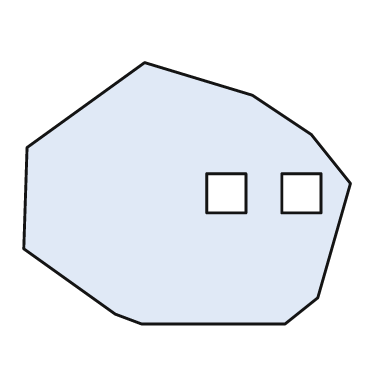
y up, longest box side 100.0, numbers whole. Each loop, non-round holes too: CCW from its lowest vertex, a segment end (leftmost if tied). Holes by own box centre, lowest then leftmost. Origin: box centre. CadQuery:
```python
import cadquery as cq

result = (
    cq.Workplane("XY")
    .moveTo(-14.0, -40.0)
    .lineTo(30.0, -40.0)
    .lineTo(40.0, -32.0)
    .lineTo(50.0, 3.0)
    .lineTo(38.0, 18.0)
    .lineTo(20.0, 30.0)
    .lineTo(-13.0, 40.0)
    .lineTo(-49.0, 14.0)
    .lineTo(-50.0, -17.0)
    .lineTo(-22.0, -37.0)
    .close()
    .moveTo(6.0, -6.0)
    .lineTo(18.0, -6.0)
    .lineTo(18.0, 6.0)
    .lineTo(6.0, 6.0)
    .close()
    .moveTo(29.0, -6.0)
    .lineTo(41.0, -6.0)
    .lineTo(41.0, 6.0)
    .lineTo(29.0, 6.0)
    .close()
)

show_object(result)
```